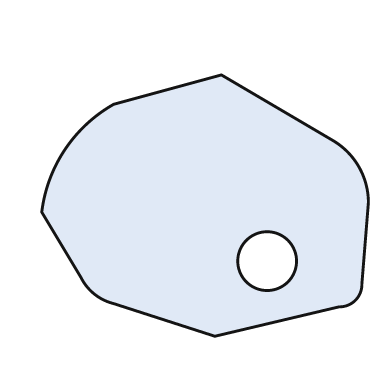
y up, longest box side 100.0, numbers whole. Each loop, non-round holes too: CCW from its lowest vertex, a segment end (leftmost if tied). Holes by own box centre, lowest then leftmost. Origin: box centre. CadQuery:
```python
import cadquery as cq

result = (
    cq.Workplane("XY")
    .moveTo(3.0, -40.0)
    .lineTo(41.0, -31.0)
    .threePointArc((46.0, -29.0), (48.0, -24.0))
    .lineTo(50.0, 1.0)
    .threePointArc((47.0, 12.0), (39.0, 20.0))
    .lineTo(5.0, 40.0)
    .lineTo(-28.0, 31.0)
    .threePointArc((-43.0, 17.0), (-50.0, -2.0))
    .lineTo(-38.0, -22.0)
    .threePointArc((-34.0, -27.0), (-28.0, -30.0))
    .close()
    .moveTo(19.0, -17.0)
    .circle(9.0)
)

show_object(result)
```